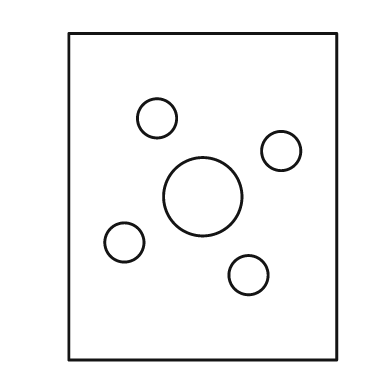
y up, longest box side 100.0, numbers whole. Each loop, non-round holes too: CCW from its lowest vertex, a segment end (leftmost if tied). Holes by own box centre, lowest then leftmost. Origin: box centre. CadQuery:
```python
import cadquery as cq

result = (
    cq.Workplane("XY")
    .moveTo(-41.0, -50.0)
    .lineTo(41.0, -50.0)
    .lineTo(41.0, 50.0)
    .lineTo(-41.0, 50.0)
    .close()
    .moveTo(14.0, -24.0)
    .circle(6.0)
    .moveTo(-24.0, -14.0)
    .circle(6.0)
    .moveTo(0.0, 0.0)
    .circle(12.0)
    .moveTo(24.0, 14.0)
    .circle(6.0)
    .moveTo(-14.0, 24.0)
    .circle(6.0)
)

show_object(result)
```